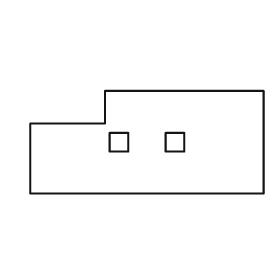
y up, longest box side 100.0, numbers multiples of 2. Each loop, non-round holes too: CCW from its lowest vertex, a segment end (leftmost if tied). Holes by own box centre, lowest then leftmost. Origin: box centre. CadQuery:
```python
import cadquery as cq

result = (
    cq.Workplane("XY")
    .moveTo(-50.0, -22.0)
    .lineTo(50.0, -22.0)
    .lineTo(50.0, 22.0)
    .lineTo(-18.0, 22.0)
    .lineTo(-18.0, 8.0)
    .lineTo(-50.0, 8.0)
    .close()
    .moveTo(-16.0, -4.0)
    .lineTo(-8.0, -4.0)
    .lineTo(-8.0, 4.0)
    .lineTo(-16.0, 4.0)
    .close()
    .moveTo(8.0, -4.0)
    .lineTo(16.0, -4.0)
    .lineTo(16.0, 4.0)
    .lineTo(8.0, 4.0)
    .close()
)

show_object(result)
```